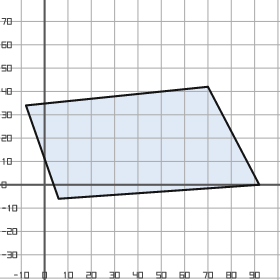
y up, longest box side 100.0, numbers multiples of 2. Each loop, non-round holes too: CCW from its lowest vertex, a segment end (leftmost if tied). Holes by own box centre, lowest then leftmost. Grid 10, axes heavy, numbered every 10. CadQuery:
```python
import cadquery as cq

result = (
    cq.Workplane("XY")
    .moveTo(6.0, -6.0)
    .lineTo(92.0, 0.0)
    .lineTo(70.0, 42.0)
    .lineTo(-8.0, 34.0)
    .close()
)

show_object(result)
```